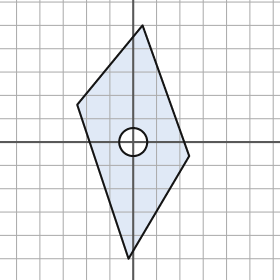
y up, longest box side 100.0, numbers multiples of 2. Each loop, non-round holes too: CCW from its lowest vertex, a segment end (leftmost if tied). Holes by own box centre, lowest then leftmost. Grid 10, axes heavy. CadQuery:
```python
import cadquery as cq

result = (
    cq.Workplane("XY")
    .moveTo(-2.0, -50.0)
    .lineTo(24.0, -6.0)
    .lineTo(4.0, 50.0)
    .lineTo(-24.0, 16.0)
    .close()
    .moveTo(0.0, 0.0)
    .circle(6.0)
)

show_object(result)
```